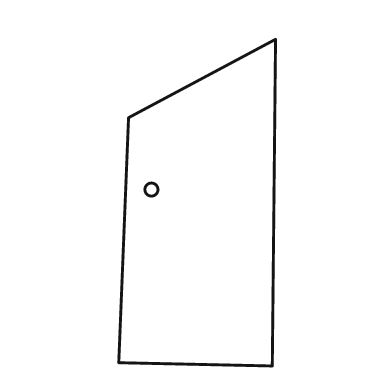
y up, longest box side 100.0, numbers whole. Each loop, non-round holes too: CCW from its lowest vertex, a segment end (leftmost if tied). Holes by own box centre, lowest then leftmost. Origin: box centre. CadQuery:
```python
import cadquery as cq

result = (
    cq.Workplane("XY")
    .moveTo(23.0, -50.0)
    .lineTo(24.0, 50.0)
    .lineTo(-21.0, 26.0)
    .lineTo(-24.0, -49.0)
    .close()
    .moveTo(-14.0, 4.0)
    .circle(2.0)
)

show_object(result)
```